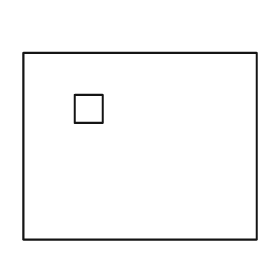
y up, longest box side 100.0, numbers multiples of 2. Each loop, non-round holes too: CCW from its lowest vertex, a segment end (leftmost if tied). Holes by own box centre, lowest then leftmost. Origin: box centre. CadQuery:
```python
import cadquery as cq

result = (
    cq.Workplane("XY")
    .moveTo(-50.0, -40.0)
    .lineTo(50.0, -40.0)
    .lineTo(50.0, 40.0)
    .lineTo(-50.0, 40.0)
    .close()
    .moveTo(-28.0, 10.0)
    .lineTo(-16.0, 10.0)
    .lineTo(-16.0, 22.0)
    .lineTo(-28.0, 22.0)
    .close()
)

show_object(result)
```